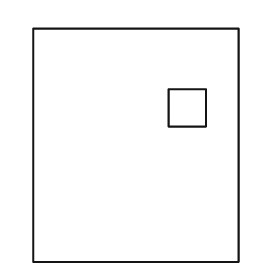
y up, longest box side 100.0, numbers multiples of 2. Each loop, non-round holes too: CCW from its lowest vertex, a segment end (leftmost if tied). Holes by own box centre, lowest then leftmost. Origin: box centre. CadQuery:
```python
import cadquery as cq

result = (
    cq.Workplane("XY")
    .moveTo(-44.0, -50.0)
    .lineTo(44.0, -50.0)
    .lineTo(44.0, 50.0)
    .lineTo(-44.0, 50.0)
    .close()
    .moveTo(14.0, 8.0)
    .lineTo(30.0, 8.0)
    .lineTo(30.0, 24.0)
    .lineTo(14.0, 24.0)
    .close()
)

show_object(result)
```